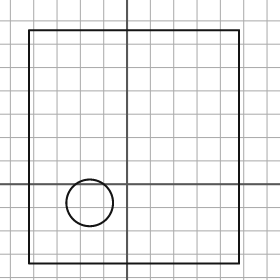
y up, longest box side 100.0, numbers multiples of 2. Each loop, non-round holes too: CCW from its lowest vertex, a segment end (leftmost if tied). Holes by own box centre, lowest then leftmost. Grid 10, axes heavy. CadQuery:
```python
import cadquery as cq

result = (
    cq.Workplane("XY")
    .moveTo(-42.0, -34.0)
    .lineTo(48.0, -34.0)
    .lineTo(48.0, 66.0)
    .lineTo(-42.0, 66.0)
    .close()
    .moveTo(-16.0, -8.0)
    .circle(10.0)
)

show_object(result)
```